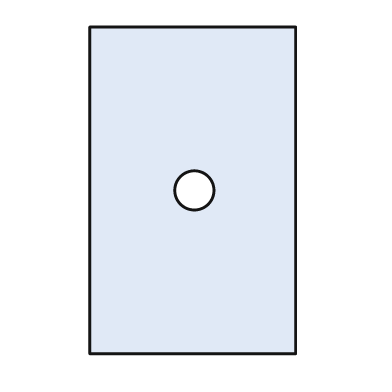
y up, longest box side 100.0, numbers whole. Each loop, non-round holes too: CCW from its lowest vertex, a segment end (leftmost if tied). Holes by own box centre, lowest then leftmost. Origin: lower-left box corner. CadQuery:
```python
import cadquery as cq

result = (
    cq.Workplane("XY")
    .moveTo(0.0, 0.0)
    .lineTo(63.0, 0.0)
    .lineTo(63.0, 100.0)
    .lineTo(0.0, 100.0)
    .close()
    .moveTo(32.0, 50.0)
    .circle(6.0)
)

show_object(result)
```